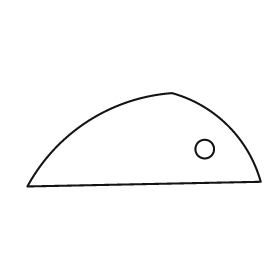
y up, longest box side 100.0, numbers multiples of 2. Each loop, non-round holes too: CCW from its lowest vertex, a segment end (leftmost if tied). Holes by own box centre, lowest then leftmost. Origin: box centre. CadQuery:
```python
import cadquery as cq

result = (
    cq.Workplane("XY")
    .moveTo(-50.0, -20.0)
    .lineTo(50.0, -18.0)
    .threePointArc((36.0, 6.0), (12.0, 20.0))
    .threePointArc((-24.0, 8.0), (-50.0, -20.0))
    .close()
    .moveTo(26.0, -4.0)
    .circle(4.0)
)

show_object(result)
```